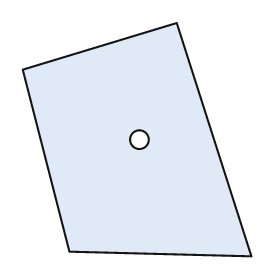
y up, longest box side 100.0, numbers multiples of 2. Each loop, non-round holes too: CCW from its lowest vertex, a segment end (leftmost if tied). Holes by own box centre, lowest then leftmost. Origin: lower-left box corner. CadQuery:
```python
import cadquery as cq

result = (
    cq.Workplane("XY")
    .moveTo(98.0, 0.0)
    .lineTo(66.0, 100.0)
    .lineTo(0.0, 80.0)
    .lineTo(20.0, 2.0)
    .close()
    .moveTo(50.0, 50.0)
    .circle(4.0)
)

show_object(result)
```